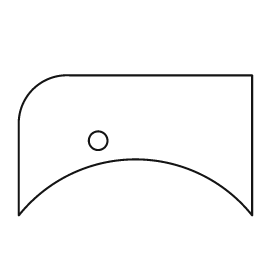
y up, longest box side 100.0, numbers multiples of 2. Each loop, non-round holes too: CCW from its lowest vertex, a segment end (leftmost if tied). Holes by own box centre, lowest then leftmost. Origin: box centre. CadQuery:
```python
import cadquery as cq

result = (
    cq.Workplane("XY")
    .moveTo(-50.0, -30.0)
    .threePointArc((0.0, -6.0), (50.0, -30.0))
    .lineTo(50.0, 30.0)
    .lineTo(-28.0, 30.0)
    .threePointArc((-44.0, 24.0), (-50.0, 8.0))
    .close()
    .moveTo(-16.0, 2.0)
    .circle(4.0)
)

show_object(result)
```